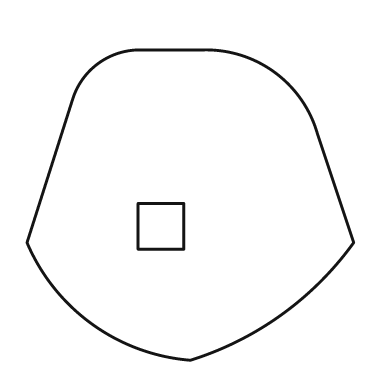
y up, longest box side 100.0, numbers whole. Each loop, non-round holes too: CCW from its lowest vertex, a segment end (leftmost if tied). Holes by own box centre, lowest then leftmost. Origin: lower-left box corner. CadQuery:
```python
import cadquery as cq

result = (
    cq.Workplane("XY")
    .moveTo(50.0, 0.0)
    .threePointArc((78.0, 14.0), (100.0, 36.0))
    .lineTo(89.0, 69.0)
    .threePointArc((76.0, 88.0), (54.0, 95.0))
    .lineTo(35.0, 95.0)
    .threePointArc((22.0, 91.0), (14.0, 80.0))
    .lineTo(0.0, 36.0)
    .threePointArc((20.0, 11.0), (50.0, 0.0))
    .close()
    .moveTo(34.0, 34.0)
    .lineTo(48.0, 34.0)
    .lineTo(48.0, 48.0)
    .lineTo(34.0, 48.0)
    .close()
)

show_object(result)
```